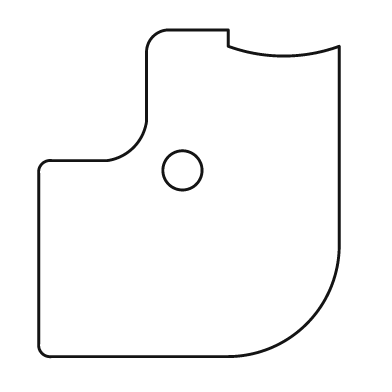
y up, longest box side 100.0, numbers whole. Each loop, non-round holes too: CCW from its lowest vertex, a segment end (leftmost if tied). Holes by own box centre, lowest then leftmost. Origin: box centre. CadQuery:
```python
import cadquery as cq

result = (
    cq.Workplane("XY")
    .moveTo(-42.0, -50.0)
    .lineTo(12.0, -50.0)
    .threePointArc((36.0, -40.0), (46.0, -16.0))
    .lineTo(46.0, 45.0)
    .threePointArc((29.0, 42.0), (12.0, 45.0))
    .lineTo(12.0, 50.0)
    .lineTo(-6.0, 50.0)
    .threePointArc((-11.0, 48.0), (-13.0, 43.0))
    .lineTo(-13.0, 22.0)
    .threePointArc((-17.0, 14.0), (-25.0, 10.0))
    .lineTo(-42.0, 10.0)
    .threePointArc((-45.0, 9.0), (-46.0, 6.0))
    .lineTo(-46.0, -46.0)
    .threePointArc((-45.0, -49.0), (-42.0, -50.0))
    .close()
    .moveTo(-2.0, 7.0)
    .circle(6.0)
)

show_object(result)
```